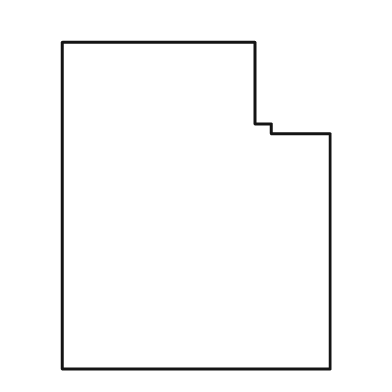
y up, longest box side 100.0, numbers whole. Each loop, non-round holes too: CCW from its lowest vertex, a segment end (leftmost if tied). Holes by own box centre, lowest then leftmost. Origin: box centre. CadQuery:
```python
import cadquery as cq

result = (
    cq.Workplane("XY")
    .moveTo(-41.0, -50.0)
    .lineTo(41.0, -50.0)
    .lineTo(41.0, 22.0)
    .lineTo(23.0, 22.0)
    .lineTo(23.0, 25.0)
    .lineTo(18.0, 25.0)
    .lineTo(18.0, 50.0)
    .lineTo(-41.0, 50.0)
    .close()
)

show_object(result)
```